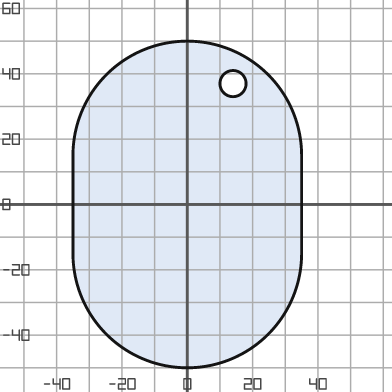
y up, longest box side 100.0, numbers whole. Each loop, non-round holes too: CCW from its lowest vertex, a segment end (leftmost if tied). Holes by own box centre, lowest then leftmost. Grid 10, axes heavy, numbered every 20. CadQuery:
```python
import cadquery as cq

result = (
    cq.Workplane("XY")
    .moveTo(-35.0, -15.0)
    .threePointArc((0.0, -50.0), (35.0, -15.0))
    .lineTo(35.0, 15.0)
    .threePointArc((0.0, 50.0), (-35.0, 15.0))
    .close()
    .moveTo(14.0, 37.0)
    .circle(4.0)
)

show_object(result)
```